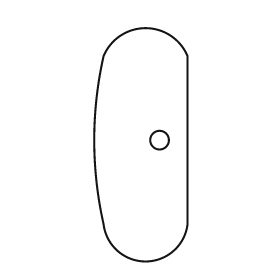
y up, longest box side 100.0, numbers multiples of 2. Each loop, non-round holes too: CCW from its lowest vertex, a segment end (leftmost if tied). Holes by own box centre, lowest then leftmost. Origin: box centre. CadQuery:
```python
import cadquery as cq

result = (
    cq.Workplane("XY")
    .moveTo(-16.0, -34.0)
    .threePointArc((2.0, -50.0), (20.0, -34.0))
    .lineTo(20.0, 38.0)
    .threePointArc((2.0, 50.0), (-16.0, 38.0))
    .threePointArc((-20.0, 2.0), (-16.0, -34.0))
    .close()
    .moveTo(8.0, 2.0)
    .circle(4.0)
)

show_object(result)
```